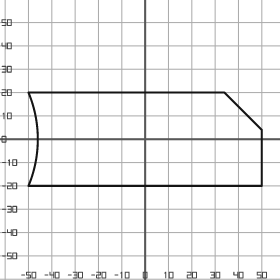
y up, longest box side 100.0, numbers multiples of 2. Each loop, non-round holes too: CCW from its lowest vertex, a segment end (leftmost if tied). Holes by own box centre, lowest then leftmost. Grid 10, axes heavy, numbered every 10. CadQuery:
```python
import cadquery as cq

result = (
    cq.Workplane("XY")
    .moveTo(-50.0, -20.0)
    .lineTo(50.0, -20.0)
    .lineTo(50.0, 4.0)
    .lineTo(34.0, 20.0)
    .lineTo(-50.0, 20.0)
    .threePointArc((-46.0, 0.0), (-50.0, -20.0))
    .close()
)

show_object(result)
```